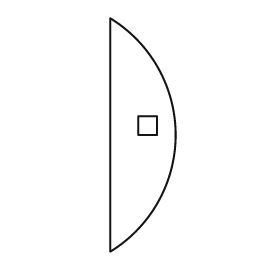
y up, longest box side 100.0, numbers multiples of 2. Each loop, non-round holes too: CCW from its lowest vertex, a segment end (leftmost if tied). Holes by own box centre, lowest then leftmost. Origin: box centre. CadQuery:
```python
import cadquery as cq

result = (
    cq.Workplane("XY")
    .moveTo(-14.0, -50.0)
    .threePointArc((14.0, 0.0), (-14.0, 50.0))
    .close()
    .moveTo(-2.0, 0.0)
    .lineTo(6.0, 0.0)
    .lineTo(6.0, 8.0)
    .lineTo(-2.0, 8.0)
    .close()
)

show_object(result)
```